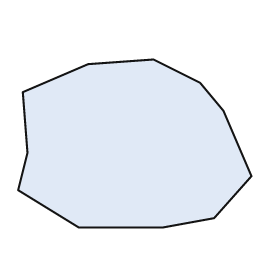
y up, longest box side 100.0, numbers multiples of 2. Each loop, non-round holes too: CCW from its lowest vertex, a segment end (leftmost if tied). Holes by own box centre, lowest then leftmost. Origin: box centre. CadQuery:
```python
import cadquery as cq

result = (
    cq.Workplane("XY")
    .moveTo(-24.0, -36.0)
    .lineTo(12.0, -36.0)
    .lineTo(34.0, -32.0)
    .lineTo(50.0, -14.0)
    .lineTo(38.0, 14.0)
    .lineTo(28.0, 26.0)
    .lineTo(8.0, 36.0)
    .lineTo(-20.0, 34.0)
    .lineTo(-48.0, 22.0)
    .lineTo(-46.0, -4.0)
    .lineTo(-50.0, -20.0)
    .close()
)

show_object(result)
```